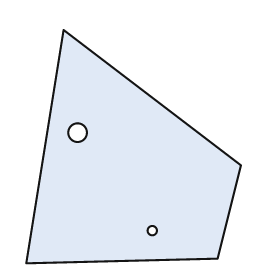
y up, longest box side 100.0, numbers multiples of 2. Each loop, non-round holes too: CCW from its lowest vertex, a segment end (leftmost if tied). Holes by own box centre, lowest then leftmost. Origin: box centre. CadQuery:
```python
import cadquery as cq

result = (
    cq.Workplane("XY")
    .moveTo(-46.0, -50.0)
    .lineTo(36.0, -48.0)
    .lineTo(46.0, -8.0)
    .lineTo(-30.0, 50.0)
    .close()
    .moveTo(8.0, -36.0)
    .circle(2.0)
    .moveTo(-24.0, 6.0)
    .circle(4.0)
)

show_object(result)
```